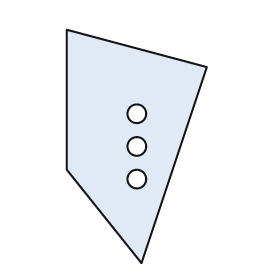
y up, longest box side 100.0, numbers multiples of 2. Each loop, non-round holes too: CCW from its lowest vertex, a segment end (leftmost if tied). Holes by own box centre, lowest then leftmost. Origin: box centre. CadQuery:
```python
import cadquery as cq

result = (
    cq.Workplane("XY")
    .moveTo(2.0, -50.0)
    .lineTo(30.0, 34.0)
    .lineTo(-30.0, 50.0)
    .lineTo(-30.0, -10.0)
    .close()
    .moveTo(0.0, -14.0)
    .circle(4.0)
    .moveTo(0.0, 0.0)
    .circle(4.0)
    .moveTo(0.0, 14.0)
    .circle(4.0)
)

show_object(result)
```